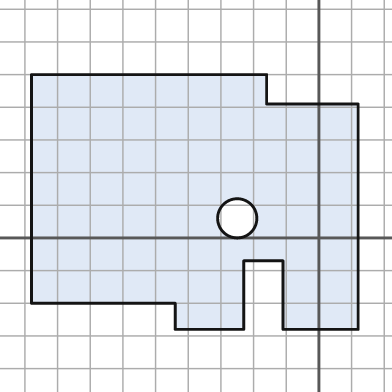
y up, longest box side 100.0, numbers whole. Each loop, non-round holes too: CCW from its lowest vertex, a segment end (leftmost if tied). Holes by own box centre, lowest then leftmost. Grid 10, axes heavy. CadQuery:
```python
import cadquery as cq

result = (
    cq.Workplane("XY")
    .moveTo(-44.0, -28.0)
    .lineTo(-23.0, -28.0)
    .lineTo(-23.0, -7.0)
    .lineTo(-11.0, -7.0)
    .lineTo(-11.0, -28.0)
    .lineTo(12.0, -28.0)
    .lineTo(12.0, 41.0)
    .lineTo(-16.0, 41.0)
    .lineTo(-16.0, 50.0)
    .lineTo(-88.0, 50.0)
    .lineTo(-88.0, -20.0)
    .lineTo(-44.0, -20.0)
    .close()
    .moveTo(-25.0, 6.0)
    .circle(6.0)
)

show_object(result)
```